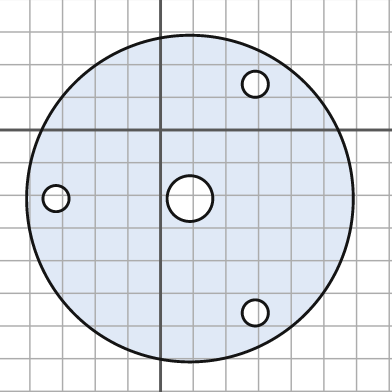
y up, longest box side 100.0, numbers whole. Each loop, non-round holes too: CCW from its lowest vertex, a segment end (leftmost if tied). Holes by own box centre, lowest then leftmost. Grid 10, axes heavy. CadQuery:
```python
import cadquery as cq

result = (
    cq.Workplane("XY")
    .moveTo(9.0, -21.0)
    .circle(50.0)
    .moveTo(29.0, -56.0)
    .circle(4.0)
    .moveTo(-32.0, -21.0)
    .circle(4.0)
    .moveTo(9.0, -21.0)
    .circle(7.0)
    .moveTo(29.0, 14.0)
    .circle(4.0)
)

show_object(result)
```